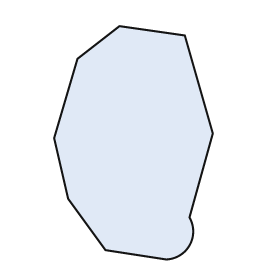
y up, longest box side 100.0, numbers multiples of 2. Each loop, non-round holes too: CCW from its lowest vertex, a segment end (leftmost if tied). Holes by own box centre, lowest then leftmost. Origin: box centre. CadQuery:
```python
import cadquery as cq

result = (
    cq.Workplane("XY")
    .moveTo(14.0, -50.0)
    .threePointArc((24.0, -44.0), (24.0, -32.0))
    .lineTo(34.0, 4.0)
    .lineTo(22.0, 46.0)
    .lineTo(-6.0, 50.0)
    .lineTo(-24.0, 36.0)
    .lineTo(-34.0, 2.0)
    .lineTo(-28.0, -24.0)
    .lineTo(-12.0, -46.0)
    .close()
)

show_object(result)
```